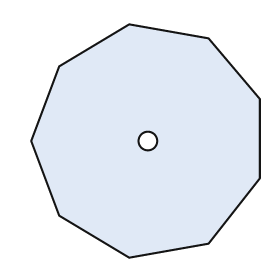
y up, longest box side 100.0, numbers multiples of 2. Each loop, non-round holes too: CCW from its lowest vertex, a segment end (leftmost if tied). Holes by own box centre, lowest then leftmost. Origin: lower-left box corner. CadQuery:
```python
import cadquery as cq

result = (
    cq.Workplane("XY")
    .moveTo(42.0, 0.0)
    .lineTo(76.0, 6.0)
    .lineTo(98.0, 34.0)
    .lineTo(98.0, 68.0)
    .lineTo(76.0, 94.0)
    .lineTo(42.0, 100.0)
    .lineTo(12.0, 82.0)
    .lineTo(0.0, 50.0)
    .lineTo(12.0, 18.0)
    .close()
    .moveTo(50.0, 50.0)
    .circle(4.0)
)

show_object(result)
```